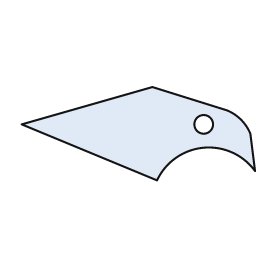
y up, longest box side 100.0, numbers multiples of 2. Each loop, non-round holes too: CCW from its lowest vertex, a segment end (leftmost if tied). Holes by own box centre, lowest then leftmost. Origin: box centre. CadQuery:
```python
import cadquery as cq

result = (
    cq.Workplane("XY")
    .moveTo(8.0, -20.0)
    .threePointArc((28.0, -6.0), (50.0, -16.0))
    .lineTo(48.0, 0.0)
    .threePointArc((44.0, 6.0), (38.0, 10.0))
    .lineTo(6.0, 20.0)
    .lineTo(-50.0, 4.0)
    .close()
    .moveTo(28.0, 4.0)
    .circle(4.0)
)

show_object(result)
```